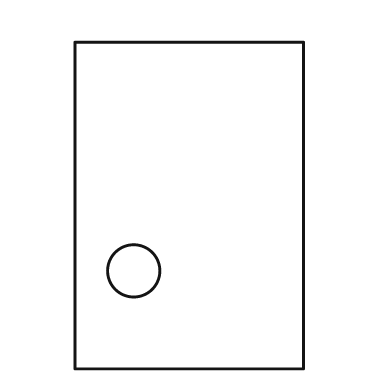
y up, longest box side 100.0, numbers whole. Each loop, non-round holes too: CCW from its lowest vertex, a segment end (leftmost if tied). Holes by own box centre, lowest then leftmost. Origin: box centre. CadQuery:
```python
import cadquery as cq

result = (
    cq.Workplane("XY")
    .moveTo(-35.0, -50.0)
    .lineTo(35.0, -50.0)
    .lineTo(35.0, 50.0)
    .lineTo(-35.0, 50.0)
    .close()
    .moveTo(-17.0, -20.0)
    .circle(8.0)
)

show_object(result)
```